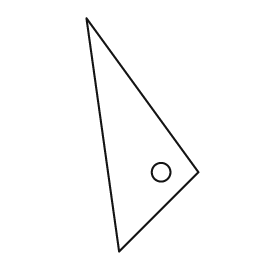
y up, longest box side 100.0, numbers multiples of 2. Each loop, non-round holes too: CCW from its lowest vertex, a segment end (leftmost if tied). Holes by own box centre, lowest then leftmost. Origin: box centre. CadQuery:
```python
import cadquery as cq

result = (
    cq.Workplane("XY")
    .moveTo(-10.0, -50.0)
    .lineTo(24.0, -16.0)
    .lineTo(-24.0, 50.0)
    .close()
    .moveTo(8.0, -16.0)
    .circle(4.0)
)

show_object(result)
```